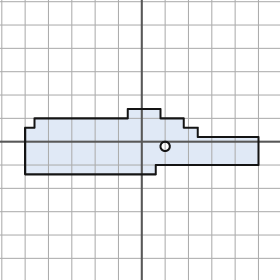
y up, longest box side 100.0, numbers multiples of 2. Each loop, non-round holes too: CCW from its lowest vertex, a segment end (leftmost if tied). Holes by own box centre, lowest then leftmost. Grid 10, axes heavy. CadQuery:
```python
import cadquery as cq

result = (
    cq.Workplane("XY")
    .moveTo(-50.0, -14.0)
    .lineTo(6.0, -14.0)
    .lineTo(6.0, -10.0)
    .lineTo(50.0, -10.0)
    .lineTo(50.0, 2.0)
    .lineTo(24.0, 2.0)
    .lineTo(24.0, 6.0)
    .lineTo(18.0, 6.0)
    .lineTo(18.0, 10.0)
    .lineTo(8.0, 10.0)
    .lineTo(8.0, 14.0)
    .lineTo(-6.0, 14.0)
    .lineTo(-6.0, 10.0)
    .lineTo(-46.0, 10.0)
    .lineTo(-46.0, 6.0)
    .lineTo(-50.0, 6.0)
    .close()
    .moveTo(10.0, -2.0)
    .circle(2.0)
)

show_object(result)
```